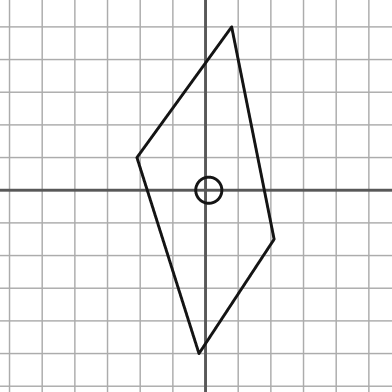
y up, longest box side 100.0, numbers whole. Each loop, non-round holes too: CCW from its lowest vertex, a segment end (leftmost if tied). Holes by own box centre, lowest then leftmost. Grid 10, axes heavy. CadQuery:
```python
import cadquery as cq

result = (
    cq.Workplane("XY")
    .moveTo(-2.0, -50.0)
    .lineTo(21.0, -15.0)
    .lineTo(8.0, 50.0)
    .lineTo(-21.0, 10.0)
    .close()
    .moveTo(1.0, 0.0)
    .circle(4.0)
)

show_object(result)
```